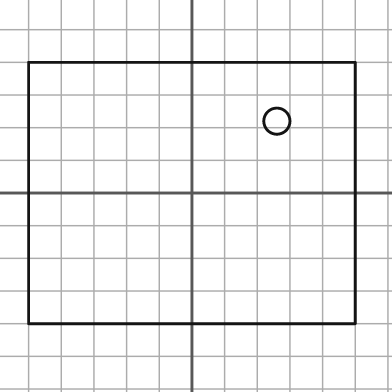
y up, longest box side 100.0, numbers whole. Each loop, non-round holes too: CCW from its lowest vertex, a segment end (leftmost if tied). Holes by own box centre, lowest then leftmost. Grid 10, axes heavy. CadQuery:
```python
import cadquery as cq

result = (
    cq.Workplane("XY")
    .moveTo(-50.0, -40.0)
    .lineTo(50.0, -40.0)
    .lineTo(50.0, 40.0)
    .lineTo(-50.0, 40.0)
    .close()
    .moveTo(26.0, 22.0)
    .circle(4.0)
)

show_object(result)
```